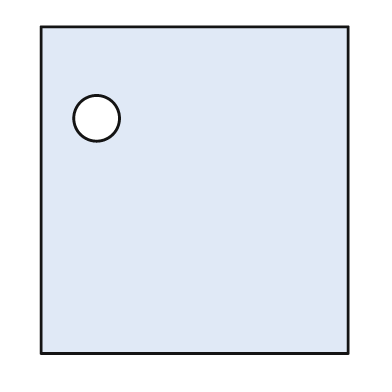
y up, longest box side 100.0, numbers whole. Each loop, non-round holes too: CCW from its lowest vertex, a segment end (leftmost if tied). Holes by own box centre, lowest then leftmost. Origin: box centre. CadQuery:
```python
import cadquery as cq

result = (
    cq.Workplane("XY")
    .moveTo(-47.0, -50.0)
    .lineTo(47.0, -50.0)
    .lineTo(47.0, 50.0)
    .lineTo(-47.0, 50.0)
    .close()
    .moveTo(-30.0, 22.0)
    .circle(7.0)
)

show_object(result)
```